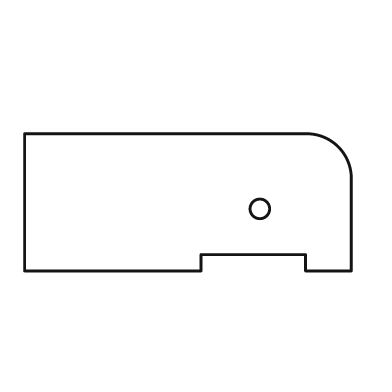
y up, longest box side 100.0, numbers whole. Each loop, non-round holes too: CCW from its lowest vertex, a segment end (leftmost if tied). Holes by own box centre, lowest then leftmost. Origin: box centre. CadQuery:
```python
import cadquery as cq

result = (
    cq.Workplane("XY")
    .moveTo(-50.0, -21.0)
    .lineTo(4.0, -21.0)
    .lineTo(4.0, -16.0)
    .lineTo(36.0, -16.0)
    .lineTo(36.0, -21.0)
    .lineTo(50.0, -21.0)
    .lineTo(50.0, 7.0)
    .threePointArc((46.0, 17.0), (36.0, 21.0))
    .lineTo(-50.0, 21.0)
    .close()
    .moveTo(22.0, -2.0)
    .circle(3.0)
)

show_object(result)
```